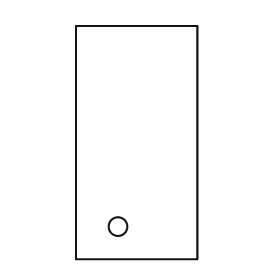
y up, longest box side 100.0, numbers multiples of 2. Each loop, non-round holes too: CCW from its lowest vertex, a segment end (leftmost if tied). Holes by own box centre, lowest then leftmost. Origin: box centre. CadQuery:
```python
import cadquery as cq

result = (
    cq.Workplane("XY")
    .moveTo(-26.0, -50.0)
    .lineTo(26.0, -50.0)
    .lineTo(26.0, 50.0)
    .lineTo(-26.0, 50.0)
    .close()
    .moveTo(-8.0, -36.0)
    .circle(4.0)
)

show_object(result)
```